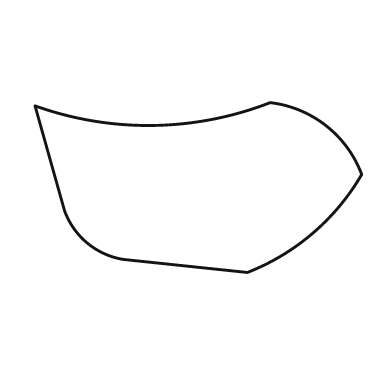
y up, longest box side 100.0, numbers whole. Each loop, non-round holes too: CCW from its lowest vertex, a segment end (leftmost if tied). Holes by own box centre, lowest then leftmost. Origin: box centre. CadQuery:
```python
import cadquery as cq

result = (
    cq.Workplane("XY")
    .moveTo(15.0, -26.0)
    .threePointArc((35.0, -14.0), (50.0, 4.0))
    .threePointArc((39.0, 19.0), (22.0, 26.0))
    .threePointArc((-14.0, 19.0), (-50.0, 25.0))
    .lineTo(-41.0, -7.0)
    .threePointArc((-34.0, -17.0), (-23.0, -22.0))
    .close()
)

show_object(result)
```